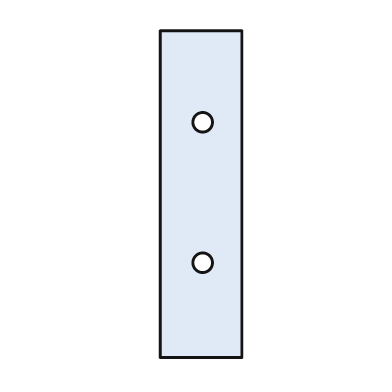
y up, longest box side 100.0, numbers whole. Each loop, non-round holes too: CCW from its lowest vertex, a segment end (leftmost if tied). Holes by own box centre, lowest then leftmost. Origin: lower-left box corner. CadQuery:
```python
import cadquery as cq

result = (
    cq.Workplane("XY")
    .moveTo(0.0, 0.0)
    .lineTo(25.0, 0.0)
    .lineTo(25.0, 100.0)
    .lineTo(0.0, 100.0)
    .close()
    .moveTo(13.0, 29.0)
    .circle(3.0)
    .moveTo(13.0, 72.0)
    .circle(3.0)
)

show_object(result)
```